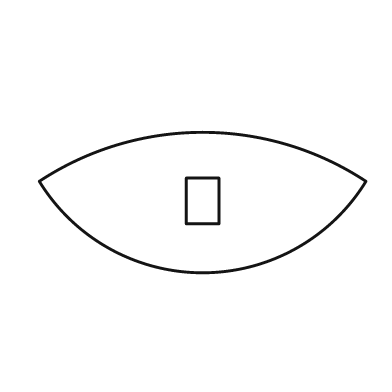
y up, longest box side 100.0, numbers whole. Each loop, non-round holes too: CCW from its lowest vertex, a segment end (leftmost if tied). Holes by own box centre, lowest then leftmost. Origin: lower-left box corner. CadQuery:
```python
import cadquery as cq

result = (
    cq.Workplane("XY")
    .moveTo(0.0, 28.0)
    .threePointArc((50.0, 0.0), (100.0, 28.0))
    .threePointArc((50.0, 43.0), (0.0, 28.0))
    .close()
    .moveTo(45.0, 15.0)
    .lineTo(55.0, 15.0)
    .lineTo(55.0, 29.0)
    .lineTo(45.0, 29.0)
    .close()
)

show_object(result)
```